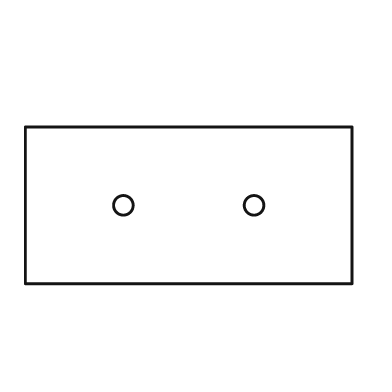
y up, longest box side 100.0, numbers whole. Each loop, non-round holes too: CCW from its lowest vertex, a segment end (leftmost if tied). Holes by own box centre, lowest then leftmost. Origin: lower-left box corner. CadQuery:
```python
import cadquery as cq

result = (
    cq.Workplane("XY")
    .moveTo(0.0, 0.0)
    .lineTo(100.0, 0.0)
    .lineTo(100.0, 48.0)
    .lineTo(0.0, 48.0)
    .close()
    .moveTo(30.0, 24.0)
    .circle(3.0)
    .moveTo(70.0, 24.0)
    .circle(3.0)
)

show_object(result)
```